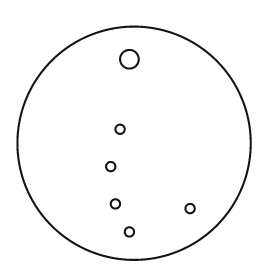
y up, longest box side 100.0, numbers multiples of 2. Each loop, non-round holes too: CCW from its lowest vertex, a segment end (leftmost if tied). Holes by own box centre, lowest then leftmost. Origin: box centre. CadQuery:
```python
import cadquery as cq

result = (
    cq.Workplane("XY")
    .moveTo(0.0, 0.0)
    .circle(50.0)
    .moveTo(-2.0, -38.0)
    .circle(2.0)
    .moveTo(24.0, -28.0)
    .circle(2.0)
    .moveTo(-8.0, -26.0)
    .circle(2.0)
    .moveTo(-10.0, -10.0)
    .circle(2.0)
    .moveTo(-6.0, 6.0)
    .circle(2.0)
    .moveTo(-2.0, 36.0)
    .circle(4.0)
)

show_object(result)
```